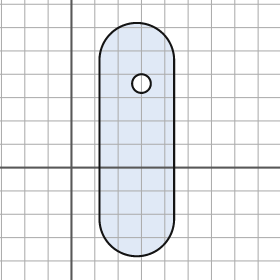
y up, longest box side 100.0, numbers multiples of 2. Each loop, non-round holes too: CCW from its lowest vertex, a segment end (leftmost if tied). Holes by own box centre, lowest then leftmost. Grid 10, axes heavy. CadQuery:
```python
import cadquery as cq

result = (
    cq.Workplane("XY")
    .moveTo(12.0, -22.0)
    .threePointArc((28.0, -38.0), (44.0, -22.0))
    .lineTo(44.0, 46.0)
    .threePointArc((28.0, 62.0), (12.0, 46.0))
    .close()
    .moveTo(30.0, 36.0)
    .circle(4.0)
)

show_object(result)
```